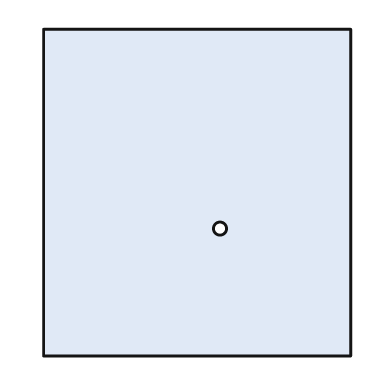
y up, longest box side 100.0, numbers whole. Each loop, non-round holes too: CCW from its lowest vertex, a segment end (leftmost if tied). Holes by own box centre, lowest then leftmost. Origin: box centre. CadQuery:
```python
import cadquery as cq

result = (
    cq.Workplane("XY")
    .moveTo(-47.0, -50.0)
    .lineTo(47.0, -50.0)
    .lineTo(47.0, 50.0)
    .lineTo(-47.0, 50.0)
    .close()
    .moveTo(7.0, -11.0)
    .circle(2.0)
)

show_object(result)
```